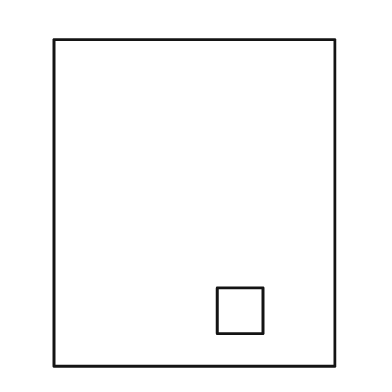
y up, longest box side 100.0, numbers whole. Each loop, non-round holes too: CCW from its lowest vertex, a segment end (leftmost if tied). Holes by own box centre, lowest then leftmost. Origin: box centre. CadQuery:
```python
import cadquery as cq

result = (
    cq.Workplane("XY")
    .moveTo(-43.0, -50.0)
    .lineTo(43.0, -50.0)
    .lineTo(43.0, 50.0)
    .lineTo(-43.0, 50.0)
    .close()
    .moveTo(7.0, -40.0)
    .lineTo(21.0, -40.0)
    .lineTo(21.0, -26.0)
    .lineTo(7.0, -26.0)
    .close()
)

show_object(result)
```